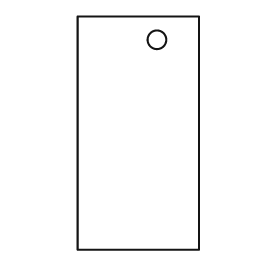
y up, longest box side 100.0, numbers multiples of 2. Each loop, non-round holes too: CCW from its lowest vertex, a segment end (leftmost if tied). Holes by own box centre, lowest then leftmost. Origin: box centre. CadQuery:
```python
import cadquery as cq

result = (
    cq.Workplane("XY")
    .moveTo(-26.0, -50.0)
    .lineTo(26.0, -50.0)
    .lineTo(26.0, 50.0)
    .lineTo(-26.0, 50.0)
    .close()
    .moveTo(8.0, 40.0)
    .circle(4.0)
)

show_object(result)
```